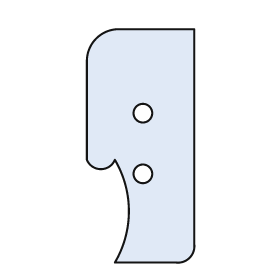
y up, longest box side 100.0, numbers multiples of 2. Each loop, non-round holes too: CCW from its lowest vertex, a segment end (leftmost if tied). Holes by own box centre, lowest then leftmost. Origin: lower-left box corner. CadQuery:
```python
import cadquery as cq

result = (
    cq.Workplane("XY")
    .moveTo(12.0, 0.0)
    .lineTo(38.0, 0.0)
    .threePointArc((44.0, 2.0), (46.0, 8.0))
    .lineTo(46.0, 100.0)
    .lineTo(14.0, 100.0)
    .threePointArc((4.0, 96.0), (0.0, 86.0))
    .lineTo(0.0, 44.0)
    .threePointArc((6.0, 40.0), (12.0, 44.0))
    .threePointArc((18.0, 22.0), (12.0, 0.0))
    .close()
    .moveTo(24.0, 38.0)
    .circle(4.0)
    .moveTo(24.0, 64.0)
    .circle(4.0)
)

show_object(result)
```